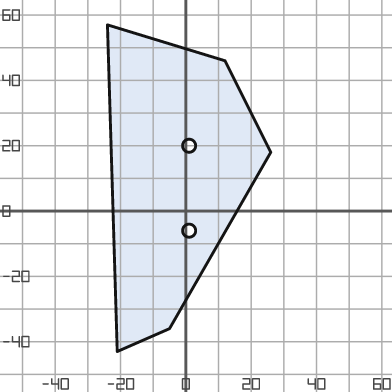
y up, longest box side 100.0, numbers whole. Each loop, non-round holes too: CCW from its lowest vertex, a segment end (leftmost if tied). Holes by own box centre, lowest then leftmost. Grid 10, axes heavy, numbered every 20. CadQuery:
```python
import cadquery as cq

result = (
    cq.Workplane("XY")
    .moveTo(-21.0, -43.0)
    .lineTo(-5.0, -36.0)
    .lineTo(26.0, 18.0)
    .lineTo(12.0, 46.0)
    .lineTo(-24.0, 57.0)
    .close()
    .moveTo(1.0, -6.0)
    .circle(2.0)
    .moveTo(1.0, 20.0)
    .circle(2.0)
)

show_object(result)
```